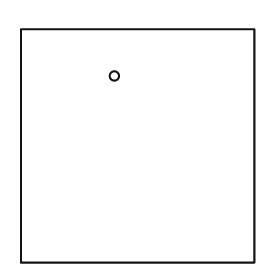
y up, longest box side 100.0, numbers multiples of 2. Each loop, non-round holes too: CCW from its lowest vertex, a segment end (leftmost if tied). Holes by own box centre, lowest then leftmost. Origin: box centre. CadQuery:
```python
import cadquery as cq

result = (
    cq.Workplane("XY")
    .moveTo(-50.0, -50.0)
    .lineTo(50.0, -50.0)
    .lineTo(50.0, 50.0)
    .lineTo(-50.0, 50.0)
    .close()
    .moveTo(-10.0, 30.0)
    .circle(2.0)
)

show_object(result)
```